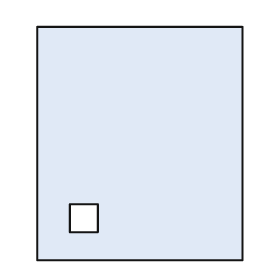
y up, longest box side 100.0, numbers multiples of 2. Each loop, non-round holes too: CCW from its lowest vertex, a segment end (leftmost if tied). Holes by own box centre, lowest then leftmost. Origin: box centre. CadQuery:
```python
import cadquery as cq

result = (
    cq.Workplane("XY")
    .moveTo(-44.0, -50.0)
    .lineTo(44.0, -50.0)
    .lineTo(44.0, 50.0)
    .lineTo(-44.0, 50.0)
    .close()
    .moveTo(-30.0, -38.0)
    .lineTo(-18.0, -38.0)
    .lineTo(-18.0, -26.0)
    .lineTo(-30.0, -26.0)
    .close()
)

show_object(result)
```